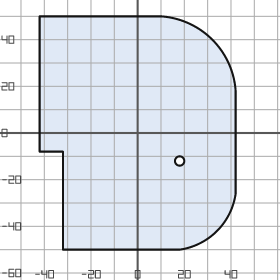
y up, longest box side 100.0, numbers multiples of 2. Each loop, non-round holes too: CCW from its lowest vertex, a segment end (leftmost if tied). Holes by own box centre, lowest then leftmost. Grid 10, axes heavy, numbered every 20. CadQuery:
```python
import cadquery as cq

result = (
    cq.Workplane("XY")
    .moveTo(-32.0, -50.0)
    .lineTo(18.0, -50.0)
    .threePointArc((34.0, -42.0), (42.0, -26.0))
    .lineTo(42.0, 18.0)
    .threePointArc((32.0, 40.0), (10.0, 50.0))
    .lineTo(-42.0, 50.0)
    .lineTo(-42.0, -8.0)
    .lineTo(-32.0, -8.0)
    .close()
    .moveTo(18.0, -12.0)
    .circle(2.0)
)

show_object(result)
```